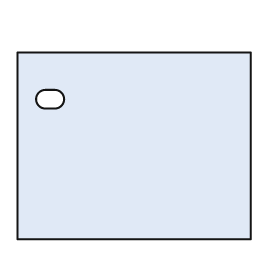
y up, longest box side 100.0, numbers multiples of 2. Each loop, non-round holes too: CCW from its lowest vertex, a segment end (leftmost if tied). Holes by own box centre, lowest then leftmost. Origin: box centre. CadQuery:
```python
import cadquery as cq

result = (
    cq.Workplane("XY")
    .moveTo(-50.0, -40.0)
    .lineTo(50.0, -40.0)
    .lineTo(50.0, 40.0)
    .lineTo(-50.0, 40.0)
    .close()
    .moveTo(-38.0, 16.0)
    .lineTo(-34.0, 16.0)
    .threePointArc((-30.0, 20.0), (-34.0, 24.0))
    .lineTo(-38.0, 24.0)
    .threePointArc((-42.0, 20.0), (-38.0, 16.0))
    .close()
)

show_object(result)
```